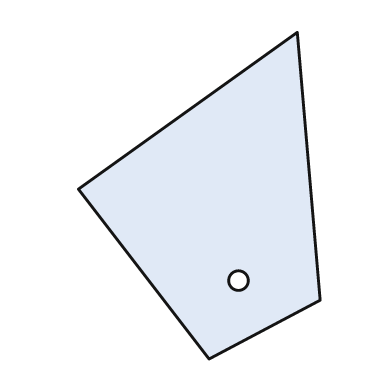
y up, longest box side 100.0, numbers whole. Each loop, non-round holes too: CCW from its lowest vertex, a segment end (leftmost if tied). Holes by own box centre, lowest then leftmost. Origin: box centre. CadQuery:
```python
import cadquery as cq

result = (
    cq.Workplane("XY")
    .moveTo(3.0, -50.0)
    .lineTo(37.0, -32.0)
    .lineTo(30.0, 50.0)
    .lineTo(-37.0, 2.0)
    .close()
    .moveTo(12.0, -26.0)
    .circle(3.0)
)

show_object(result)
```